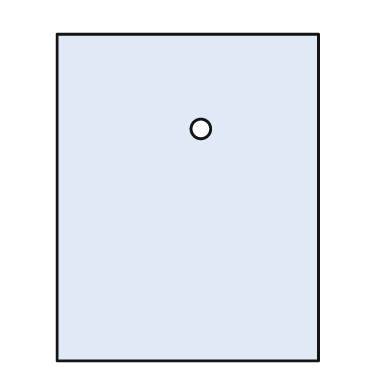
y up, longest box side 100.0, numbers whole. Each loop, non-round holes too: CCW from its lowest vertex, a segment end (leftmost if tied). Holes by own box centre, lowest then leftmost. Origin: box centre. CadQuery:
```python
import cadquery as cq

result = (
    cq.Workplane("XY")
    .moveTo(-40.0, -50.0)
    .lineTo(40.0, -50.0)
    .lineTo(40.0, 50.0)
    .lineTo(-40.0, 50.0)
    .close()
    .moveTo(4.0, 21.0)
    .circle(3.0)
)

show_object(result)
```